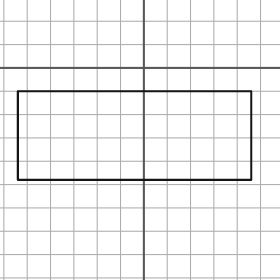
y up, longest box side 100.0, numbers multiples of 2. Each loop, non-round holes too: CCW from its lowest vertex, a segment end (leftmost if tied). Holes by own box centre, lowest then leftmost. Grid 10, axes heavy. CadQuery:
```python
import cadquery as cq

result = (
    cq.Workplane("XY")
    .moveTo(-54.0, -48.0)
    .lineTo(46.0, -48.0)
    .lineTo(46.0, -10.0)
    .lineTo(-54.0, -10.0)
    .close()
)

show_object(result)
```